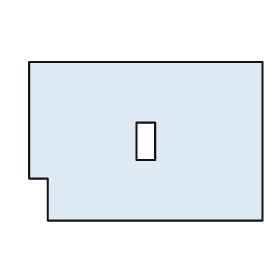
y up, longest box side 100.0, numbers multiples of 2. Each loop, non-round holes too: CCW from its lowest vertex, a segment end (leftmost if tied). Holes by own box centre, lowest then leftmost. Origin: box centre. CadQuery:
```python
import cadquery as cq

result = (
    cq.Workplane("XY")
    .moveTo(-42.0, -34.0)
    .lineTo(50.0, -34.0)
    .lineTo(50.0, 34.0)
    .lineTo(-50.0, 34.0)
    .lineTo(-50.0, -16.0)
    .lineTo(-42.0, -16.0)
    .close()
    .moveTo(-4.0, -8.0)
    .lineTo(4.0, -8.0)
    .lineTo(4.0, 8.0)
    .lineTo(-4.0, 8.0)
    .close()
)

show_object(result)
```